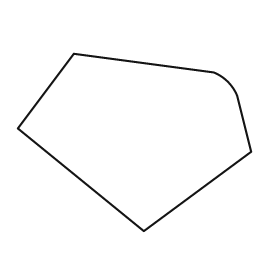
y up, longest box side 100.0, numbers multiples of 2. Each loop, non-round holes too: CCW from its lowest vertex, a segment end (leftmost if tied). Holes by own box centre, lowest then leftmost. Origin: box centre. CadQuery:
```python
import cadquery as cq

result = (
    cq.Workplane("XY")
    .moveTo(4.0, -38.0)
    .lineTo(50.0, -4.0)
    .lineTo(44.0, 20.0)
    .threePointArc((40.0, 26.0), (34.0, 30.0))
    .lineTo(-26.0, 38.0)
    .lineTo(-50.0, 6.0)
    .close()
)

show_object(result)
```